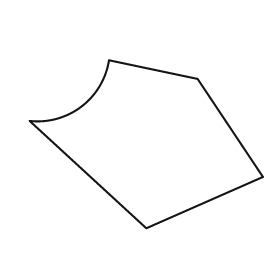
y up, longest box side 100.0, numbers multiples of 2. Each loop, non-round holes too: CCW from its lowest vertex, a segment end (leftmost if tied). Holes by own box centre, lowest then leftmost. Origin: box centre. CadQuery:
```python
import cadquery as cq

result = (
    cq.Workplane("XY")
    .moveTo(0.0, -36.0)
    .lineTo(50.0, -14.0)
    .lineTo(22.0, 28.0)
    .lineTo(-16.0, 36.0)
    .threePointArc((-28.0, 16.0), (-50.0, 10.0))
    .close()
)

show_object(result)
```